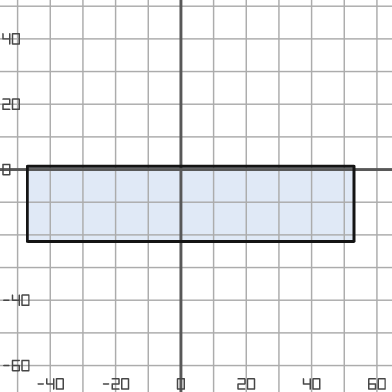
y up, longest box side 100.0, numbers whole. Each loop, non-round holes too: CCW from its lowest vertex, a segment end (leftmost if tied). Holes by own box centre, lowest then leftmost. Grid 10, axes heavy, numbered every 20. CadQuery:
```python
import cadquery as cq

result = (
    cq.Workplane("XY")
    .moveTo(-47.0, -22.0)
    .lineTo(53.0, -22.0)
    .lineTo(53.0, 1.0)
    .lineTo(-47.0, 1.0)
    .close()
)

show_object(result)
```